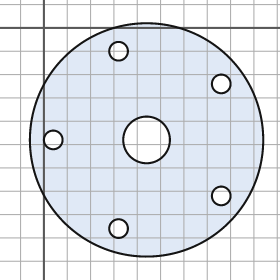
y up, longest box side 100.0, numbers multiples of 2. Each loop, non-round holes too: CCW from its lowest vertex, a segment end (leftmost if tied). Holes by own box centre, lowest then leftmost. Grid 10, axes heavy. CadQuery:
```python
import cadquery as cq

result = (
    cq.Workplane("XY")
    .moveTo(44.0, -48.0)
    .circle(50.0)
    .moveTo(32.0, -86.0)
    .circle(4.0)
    .moveTo(76.0, -72.0)
    .circle(4.0)
    .moveTo(4.0, -48.0)
    .circle(4.0)
    .moveTo(44.0, -48.0)
    .circle(10.0)
    .moveTo(76.0, -24.0)
    .circle(4.0)
    .moveTo(32.0, -10.0)
    .circle(4.0)
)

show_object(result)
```